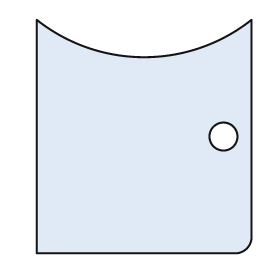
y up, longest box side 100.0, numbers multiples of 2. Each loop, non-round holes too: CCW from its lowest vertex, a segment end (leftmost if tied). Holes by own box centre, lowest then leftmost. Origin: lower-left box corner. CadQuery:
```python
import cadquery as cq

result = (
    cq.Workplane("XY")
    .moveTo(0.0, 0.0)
    .lineTo(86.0, 0.0)
    .threePointArc((90.0, 2.0), (92.0, 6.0))
    .lineTo(92.0, 100.0)
    .threePointArc((46.0, 84.0), (0.0, 100.0))
    .close()
    .moveTo(80.0, 50.0)
    .circle(6.0)
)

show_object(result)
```